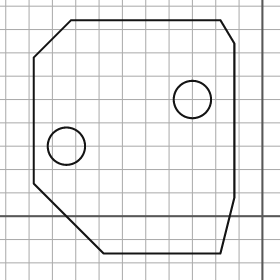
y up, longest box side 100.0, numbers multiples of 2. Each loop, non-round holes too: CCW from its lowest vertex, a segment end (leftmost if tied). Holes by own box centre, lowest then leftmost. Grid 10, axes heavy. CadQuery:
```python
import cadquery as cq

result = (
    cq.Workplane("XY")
    .moveTo(-68.0, -16.0)
    .lineTo(-18.0, -16.0)
    .lineTo(-12.0, 8.0)
    .lineTo(-12.0, 74.0)
    .lineTo(-18.0, 84.0)
    .lineTo(-82.0, 84.0)
    .lineTo(-98.0, 68.0)
    .lineTo(-98.0, 14.0)
    .close()
    .moveTo(-84.0, 30.0)
    .circle(8.0)
    .moveTo(-30.0, 50.0)
    .circle(8.0)
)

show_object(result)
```